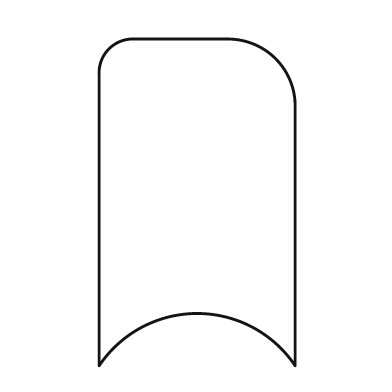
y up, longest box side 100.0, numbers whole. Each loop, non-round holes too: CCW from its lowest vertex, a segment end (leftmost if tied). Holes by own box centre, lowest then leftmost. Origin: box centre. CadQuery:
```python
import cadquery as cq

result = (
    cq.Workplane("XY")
    .moveTo(-30.0, -50.0)
    .threePointArc((0.0, -34.0), (30.0, -50.0))
    .lineTo(30.0, 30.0)
    .threePointArc((24.0, 44.0), (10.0, 50.0))
    .lineTo(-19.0, 50.0)
    .threePointArc((-27.0, 47.0), (-30.0, 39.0))
    .close()
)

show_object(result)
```